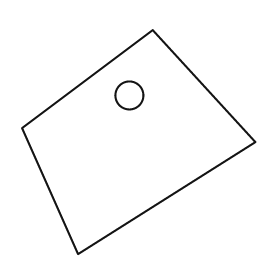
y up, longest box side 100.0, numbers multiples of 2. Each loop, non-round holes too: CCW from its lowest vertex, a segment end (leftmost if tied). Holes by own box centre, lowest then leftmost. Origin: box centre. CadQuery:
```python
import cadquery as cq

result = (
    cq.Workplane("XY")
    .moveTo(-26.0, -48.0)
    .lineTo(50.0, 0.0)
    .lineTo(6.0, 48.0)
    .lineTo(-50.0, 6.0)
    .close()
    .moveTo(-4.0, 20.0)
    .circle(6.0)
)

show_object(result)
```